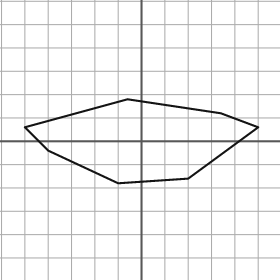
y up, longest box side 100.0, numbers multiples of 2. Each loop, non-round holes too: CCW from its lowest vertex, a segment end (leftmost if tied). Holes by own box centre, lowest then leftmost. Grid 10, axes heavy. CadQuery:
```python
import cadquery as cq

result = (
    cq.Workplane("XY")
    .moveTo(-10.0, -18.0)
    .lineTo(20.0, -16.0)
    .lineTo(50.0, 6.0)
    .lineTo(34.0, 12.0)
    .lineTo(-6.0, 18.0)
    .lineTo(-50.0, 6.0)
    .lineTo(-40.0, -4.0)
    .close()
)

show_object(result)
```